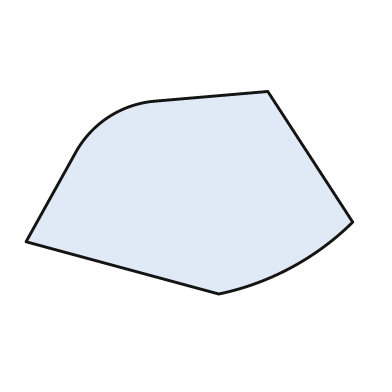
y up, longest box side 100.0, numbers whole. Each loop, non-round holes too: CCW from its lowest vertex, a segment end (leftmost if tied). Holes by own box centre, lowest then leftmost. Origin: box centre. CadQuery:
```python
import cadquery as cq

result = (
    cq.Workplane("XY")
    .moveTo(9.0, -31.0)
    .threePointArc((31.0, -23.0), (50.0, -9.0))
    .lineTo(24.0, 31.0)
    .lineTo(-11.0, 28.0)
    .threePointArc((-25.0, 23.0), (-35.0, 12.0))
    .lineTo(-50.0, -15.0)
    .close()
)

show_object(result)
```